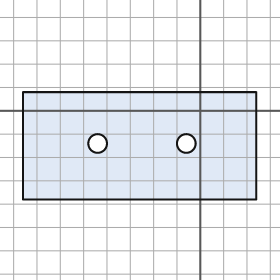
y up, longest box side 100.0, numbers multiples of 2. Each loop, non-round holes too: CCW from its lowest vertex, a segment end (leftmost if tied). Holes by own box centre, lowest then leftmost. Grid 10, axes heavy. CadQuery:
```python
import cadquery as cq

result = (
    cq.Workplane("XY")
    .moveTo(-76.0, -38.0)
    .lineTo(24.0, -38.0)
    .lineTo(24.0, 8.0)
    .lineTo(-76.0, 8.0)
    .close()
    .moveTo(-44.0, -14.0)
    .circle(4.0)
    .moveTo(-6.0, -14.0)
    .circle(4.0)
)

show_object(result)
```